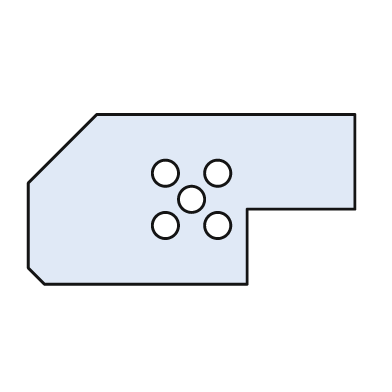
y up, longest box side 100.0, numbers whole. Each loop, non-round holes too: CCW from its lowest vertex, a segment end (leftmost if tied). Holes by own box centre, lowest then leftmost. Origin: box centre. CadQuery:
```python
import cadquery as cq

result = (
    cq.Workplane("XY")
    .moveTo(-45.0, -26.0)
    .lineTo(17.0, -26.0)
    .lineTo(17.0, -3.0)
    .lineTo(50.0, -3.0)
    .lineTo(50.0, 26.0)
    .lineTo(-29.0, 26.0)
    .lineTo(-50.0, 5.0)
    .lineTo(-50.0, -21.0)
    .close()
    .moveTo(-8.0, -8.0)
    .circle(4.0)
    .moveTo(8.0, -8.0)
    .circle(4.0)
    .moveTo(0.0, 0.0)
    .circle(4.0)
    .moveTo(-8.0, 8.0)
    .circle(4.0)
    .moveTo(8.0, 8.0)
    .circle(4.0)
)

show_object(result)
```